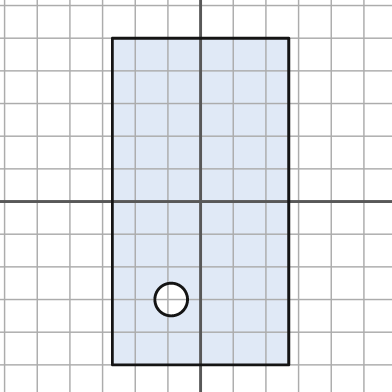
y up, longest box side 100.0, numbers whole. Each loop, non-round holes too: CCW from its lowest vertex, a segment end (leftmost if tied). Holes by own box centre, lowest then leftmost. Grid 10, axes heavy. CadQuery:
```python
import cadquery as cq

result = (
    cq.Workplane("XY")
    .moveTo(-27.0, -50.0)
    .lineTo(27.0, -50.0)
    .lineTo(27.0, 50.0)
    .lineTo(-27.0, 50.0)
    .close()
    .moveTo(-9.0, -30.0)
    .circle(5.0)
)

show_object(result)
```